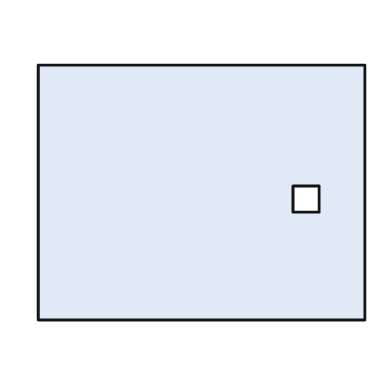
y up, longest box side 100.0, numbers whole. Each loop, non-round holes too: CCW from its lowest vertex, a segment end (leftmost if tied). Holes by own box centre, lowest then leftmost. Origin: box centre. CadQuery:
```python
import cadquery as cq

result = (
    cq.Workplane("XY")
    .moveTo(-50.0, -39.0)
    .lineTo(50.0, -39.0)
    .lineTo(50.0, 39.0)
    .lineTo(-50.0, 39.0)
    .close()
    .moveTo(28.0, -6.0)
    .lineTo(36.0, -6.0)
    .lineTo(36.0, 2.0)
    .lineTo(28.0, 2.0)
    .close()
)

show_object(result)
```